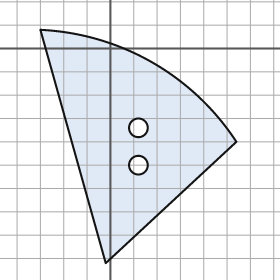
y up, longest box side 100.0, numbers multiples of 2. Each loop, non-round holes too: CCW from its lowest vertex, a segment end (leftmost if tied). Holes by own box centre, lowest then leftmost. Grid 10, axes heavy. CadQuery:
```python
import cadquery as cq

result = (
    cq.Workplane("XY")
    .moveTo(-2.0, -92.0)
    .lineTo(54.0, -40.0)
    .threePointArc((18.0, -6.0), (-30.0, 8.0))
    .close()
    .moveTo(12.0, -50.0)
    .circle(4.0)
    .moveTo(12.0, -34.0)
    .circle(4.0)
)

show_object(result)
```